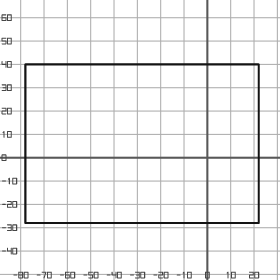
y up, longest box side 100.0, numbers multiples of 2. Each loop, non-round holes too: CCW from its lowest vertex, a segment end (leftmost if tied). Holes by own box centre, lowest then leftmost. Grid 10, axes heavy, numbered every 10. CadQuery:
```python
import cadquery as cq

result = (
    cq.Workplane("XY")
    .moveTo(-78.0, -28.0)
    .lineTo(22.0, -28.0)
    .lineTo(22.0, 40.0)
    .lineTo(-78.0, 40.0)
    .close()
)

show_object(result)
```